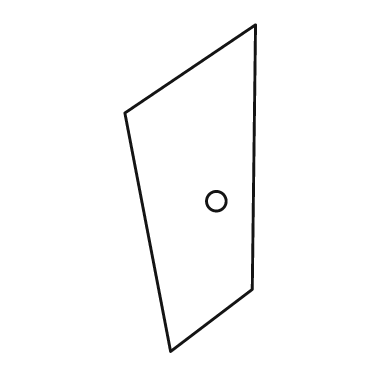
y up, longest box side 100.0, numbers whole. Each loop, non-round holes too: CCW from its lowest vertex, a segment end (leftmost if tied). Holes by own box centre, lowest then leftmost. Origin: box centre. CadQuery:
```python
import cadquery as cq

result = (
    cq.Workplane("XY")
    .moveTo(-6.0, -50.0)
    .lineTo(19.0, -31.0)
    .lineTo(20.0, 50.0)
    .lineTo(-20.0, 23.0)
    .close()
    .moveTo(8.0, -4.0)
    .circle(3.0)
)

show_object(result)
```